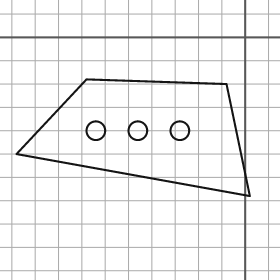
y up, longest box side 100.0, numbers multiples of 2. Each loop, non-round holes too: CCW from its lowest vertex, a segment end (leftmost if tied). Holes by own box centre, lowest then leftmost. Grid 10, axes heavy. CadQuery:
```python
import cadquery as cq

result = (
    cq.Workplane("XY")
    .moveTo(2.0, -68.0)
    .lineTo(-8.0, -20.0)
    .lineTo(-68.0, -18.0)
    .lineTo(-98.0, -50.0)
    .close()
    .moveTo(-64.0, -40.0)
    .circle(4.0)
    .moveTo(-46.0, -40.0)
    .circle(4.0)
    .moveTo(-28.0, -40.0)
    .circle(4.0)
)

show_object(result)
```